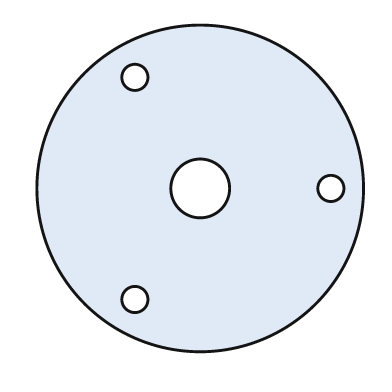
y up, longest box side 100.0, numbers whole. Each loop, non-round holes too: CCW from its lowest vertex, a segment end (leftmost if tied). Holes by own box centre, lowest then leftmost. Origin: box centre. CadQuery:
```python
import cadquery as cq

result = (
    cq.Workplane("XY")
    .moveTo(0.0, 0.0)
    .circle(50.0)
    .moveTo(-20.0, -34.0)
    .circle(4.0)
    .moveTo(0.0, 0.0)
    .circle(9.0)
    .moveTo(40.0, 0.0)
    .circle(4.0)
    .moveTo(-20.0, 34.0)
    .circle(4.0)
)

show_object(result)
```